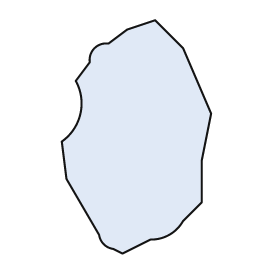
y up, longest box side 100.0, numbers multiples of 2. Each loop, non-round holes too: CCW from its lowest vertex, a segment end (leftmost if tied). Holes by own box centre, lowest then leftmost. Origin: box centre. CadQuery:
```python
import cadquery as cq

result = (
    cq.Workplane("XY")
    .moveTo(-6.0, -50.0)
    .lineTo(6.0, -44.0)
    .threePointArc((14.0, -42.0), (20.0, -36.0))
    .lineTo(28.0, -28.0)
    .lineTo(28.0, -10.0)
    .lineTo(32.0, 10.0)
    .lineTo(20.0, 38.0)
    .lineTo(8.0, 50.0)
    .lineTo(-4.0, 46.0)
    .lineTo(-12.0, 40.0)
    .threePointArc((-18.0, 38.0), (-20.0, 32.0))
    .lineTo(-26.0, 24.0)
    .threePointArc((-24.0, 10.0), (-32.0, -2.0))
    .lineTo(-30.0, -18.0)
    .lineTo(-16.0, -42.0)
    .threePointArc((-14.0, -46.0), (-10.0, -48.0))
    .close()
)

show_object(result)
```